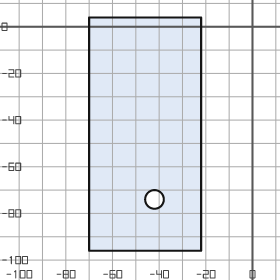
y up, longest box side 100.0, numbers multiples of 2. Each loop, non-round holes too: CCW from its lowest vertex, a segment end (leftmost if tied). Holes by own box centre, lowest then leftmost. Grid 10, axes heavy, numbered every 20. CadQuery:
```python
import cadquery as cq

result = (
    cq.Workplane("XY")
    .moveTo(-70.0, -96.0)
    .lineTo(-22.0, -96.0)
    .lineTo(-22.0, 4.0)
    .lineTo(-70.0, 4.0)
    .close()
    .moveTo(-42.0, -74.0)
    .circle(4.0)
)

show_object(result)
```